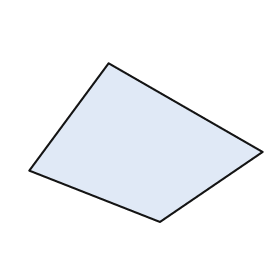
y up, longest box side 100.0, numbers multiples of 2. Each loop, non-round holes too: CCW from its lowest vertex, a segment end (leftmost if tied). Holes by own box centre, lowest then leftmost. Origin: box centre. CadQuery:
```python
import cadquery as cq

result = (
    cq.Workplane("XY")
    .moveTo(6.0, -34.0)
    .lineTo(50.0, -4.0)
    .lineTo(-16.0, 34.0)
    .lineTo(-50.0, -12.0)
    .close()
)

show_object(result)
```